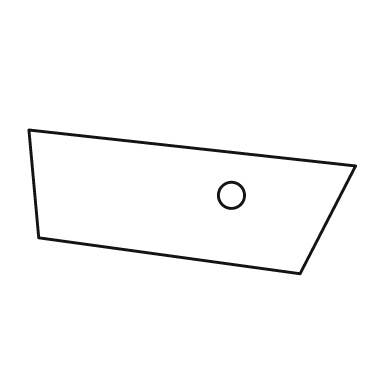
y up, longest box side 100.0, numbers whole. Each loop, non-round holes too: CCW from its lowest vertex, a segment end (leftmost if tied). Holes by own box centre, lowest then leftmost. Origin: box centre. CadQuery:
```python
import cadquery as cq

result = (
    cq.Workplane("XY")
    .moveTo(33.0, -22.0)
    .lineTo(50.0, 11.0)
    .lineTo(-50.0, 22.0)
    .lineTo(-47.0, -11.0)
    .close()
    .moveTo(12.0, 2.0)
    .circle(4.0)
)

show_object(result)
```